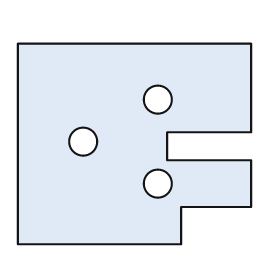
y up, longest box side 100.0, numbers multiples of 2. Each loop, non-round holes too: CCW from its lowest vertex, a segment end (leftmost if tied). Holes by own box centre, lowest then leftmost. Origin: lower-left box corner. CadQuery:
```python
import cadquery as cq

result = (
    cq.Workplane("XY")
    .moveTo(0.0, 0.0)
    .lineTo(70.0, 0.0)
    .lineTo(70.0, 16.0)
    .lineTo(100.0, 16.0)
    .lineTo(100.0, 36.0)
    .lineTo(64.0, 36.0)
    .lineTo(64.0, 48.0)
    .lineTo(100.0, 48.0)
    .lineTo(100.0, 86.0)
    .lineTo(0.0, 86.0)
    .close()
    .moveTo(60.0, 26.0)
    .circle(6.0)
    .moveTo(28.0, 44.0)
    .circle(6.0)
    .moveTo(60.0, 62.0)
    .circle(6.0)
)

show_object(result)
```